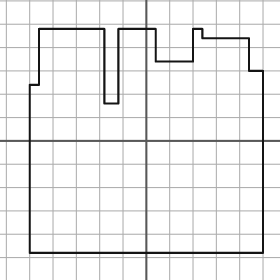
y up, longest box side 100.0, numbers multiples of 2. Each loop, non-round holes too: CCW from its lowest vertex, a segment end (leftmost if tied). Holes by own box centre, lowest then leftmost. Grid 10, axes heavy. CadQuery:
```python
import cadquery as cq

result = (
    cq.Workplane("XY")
    .moveTo(-50.0, -48.0)
    .lineTo(50.0, -48.0)
    .lineTo(50.0, 30.0)
    .lineTo(44.0, 30.0)
    .lineTo(44.0, 44.0)
    .lineTo(24.0, 44.0)
    .lineTo(24.0, 48.0)
    .lineTo(20.0, 48.0)
    .lineTo(20.0, 34.0)
    .lineTo(4.0, 34.0)
    .lineTo(4.0, 48.0)
    .lineTo(-12.0, 48.0)
    .lineTo(-12.0, 16.0)
    .lineTo(-18.0, 16.0)
    .lineTo(-18.0, 48.0)
    .lineTo(-46.0, 48.0)
    .lineTo(-46.0, 24.0)
    .lineTo(-50.0, 24.0)
    .close()
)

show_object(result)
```